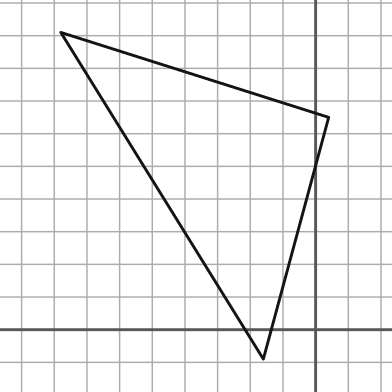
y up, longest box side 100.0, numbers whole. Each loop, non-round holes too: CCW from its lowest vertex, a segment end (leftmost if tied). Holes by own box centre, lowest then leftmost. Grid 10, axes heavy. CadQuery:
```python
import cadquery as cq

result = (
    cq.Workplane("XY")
    .moveTo(-16.0, -9.0)
    .lineTo(4.0, 65.0)
    .lineTo(-78.0, 91.0)
    .close()
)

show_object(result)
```